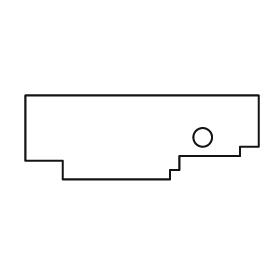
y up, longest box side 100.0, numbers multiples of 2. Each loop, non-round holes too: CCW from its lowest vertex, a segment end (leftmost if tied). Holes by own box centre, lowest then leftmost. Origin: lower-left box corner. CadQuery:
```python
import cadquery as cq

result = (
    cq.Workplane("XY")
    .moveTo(16.0, 0.0)
    .lineTo(62.0, 0.0)
    .lineTo(62.0, 4.0)
    .lineTo(66.0, 4.0)
    .lineTo(66.0, 10.0)
    .lineTo(92.0, 10.0)
    .lineTo(92.0, 14.0)
    .lineTo(100.0, 14.0)
    .lineTo(100.0, 36.0)
    .lineTo(0.0, 36.0)
    .lineTo(0.0, 8.0)
    .lineTo(16.0, 8.0)
    .close()
    .moveTo(76.0, 18.0)
    .circle(4.0)
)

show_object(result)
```